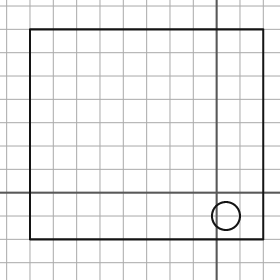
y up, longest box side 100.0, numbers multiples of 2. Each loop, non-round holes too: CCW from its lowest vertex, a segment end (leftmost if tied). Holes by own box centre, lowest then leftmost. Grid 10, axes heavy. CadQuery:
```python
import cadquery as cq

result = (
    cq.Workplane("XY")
    .moveTo(-80.0, -20.0)
    .lineTo(20.0, -20.0)
    .lineTo(20.0, 70.0)
    .lineTo(-80.0, 70.0)
    .close()
    .moveTo(4.0, -10.0)
    .circle(6.0)
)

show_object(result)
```